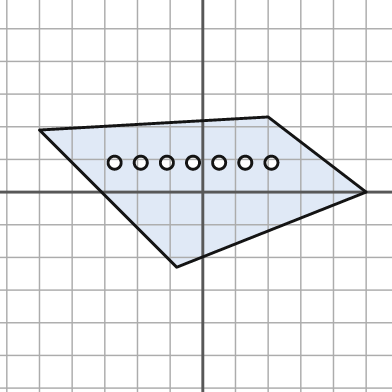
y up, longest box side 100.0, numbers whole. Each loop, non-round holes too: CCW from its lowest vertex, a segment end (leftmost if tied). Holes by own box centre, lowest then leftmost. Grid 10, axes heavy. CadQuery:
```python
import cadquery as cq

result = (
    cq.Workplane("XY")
    .moveTo(-8.0, -23.0)
    .lineTo(50.0, 0.0)
    .lineTo(20.0, 23.0)
    .lineTo(-50.0, 19.0)
    .close()
    .moveTo(-27.0, 9.0)
    .circle(2.0)
    .moveTo(-19.0, 9.0)
    .circle(2.0)
    .moveTo(-11.0, 9.0)
    .circle(2.0)
    .moveTo(-3.0, 9.0)
    .circle(2.0)
    .moveTo(5.0, 9.0)
    .circle(2.0)
    .moveTo(13.0, 9.0)
    .circle(2.0)
    .moveTo(21.0, 9.0)
    .circle(2.0)
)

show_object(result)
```